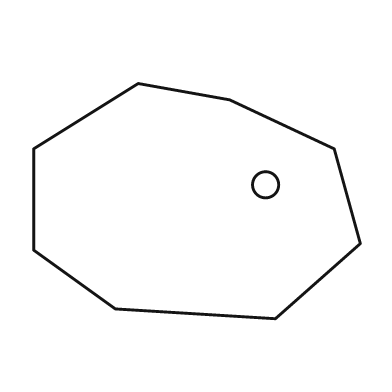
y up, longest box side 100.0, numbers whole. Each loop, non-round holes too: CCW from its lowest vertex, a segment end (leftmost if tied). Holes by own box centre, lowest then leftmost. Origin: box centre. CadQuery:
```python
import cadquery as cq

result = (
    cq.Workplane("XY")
    .moveTo(24.0, -36.0)
    .lineTo(50.0, -13.0)
    .lineTo(42.0, 16.0)
    .lineTo(10.0, 31.0)
    .lineTo(-18.0, 36.0)
    .lineTo(-50.0, 16.0)
    .lineTo(-50.0, -15.0)
    .lineTo(-25.0, -33.0)
    .close()
    .moveTo(21.0, 5.0)
    .circle(4.0)
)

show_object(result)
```